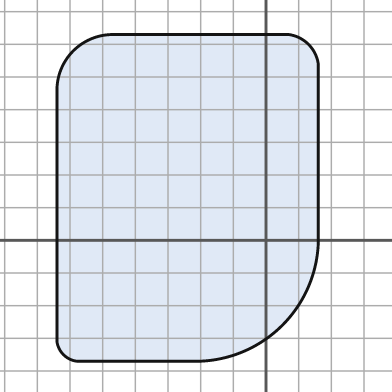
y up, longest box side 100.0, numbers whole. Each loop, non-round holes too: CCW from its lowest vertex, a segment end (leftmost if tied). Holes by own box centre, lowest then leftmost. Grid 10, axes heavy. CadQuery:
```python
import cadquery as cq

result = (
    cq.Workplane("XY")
    .moveTo(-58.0, -37.0)
    .lineTo(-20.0, -37.0)
    .threePointArc((5.0, -26.0), (16.0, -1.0))
    .lineTo(16.0, 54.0)
    .threePointArc((13.0, 60.0), (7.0, 63.0))
    .lineTo(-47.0, 63.0)
    .threePointArc((-59.0, 58.0), (-64.0, 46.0))
    .lineTo(-64.0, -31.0)
    .threePointArc((-62.0, -35.0), (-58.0, -37.0))
    .close()
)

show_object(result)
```